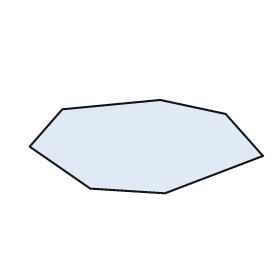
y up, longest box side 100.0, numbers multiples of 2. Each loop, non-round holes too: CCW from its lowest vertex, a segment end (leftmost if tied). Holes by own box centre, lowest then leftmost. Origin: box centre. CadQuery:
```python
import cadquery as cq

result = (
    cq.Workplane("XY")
    .moveTo(8.0, -20.0)
    .lineTo(50.0, -4.0)
    .lineTo(34.0, 14.0)
    .lineTo(6.0, 20.0)
    .lineTo(-36.0, 16.0)
    .lineTo(-50.0, 0.0)
    .lineTo(-24.0, -18.0)
    .close()
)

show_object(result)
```